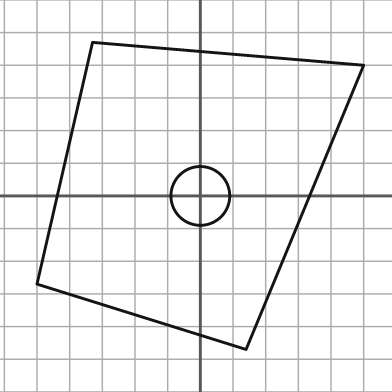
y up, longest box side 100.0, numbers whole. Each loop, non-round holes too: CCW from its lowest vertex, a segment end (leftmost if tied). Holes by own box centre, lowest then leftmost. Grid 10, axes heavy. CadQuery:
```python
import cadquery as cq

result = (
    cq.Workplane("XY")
    .moveTo(14.0, -47.0)
    .lineTo(50.0, 40.0)
    .lineTo(-33.0, 47.0)
    .lineTo(-50.0, -27.0)
    .close()
    .moveTo(0.0, 0.0)
    .circle(9.0)
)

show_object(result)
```